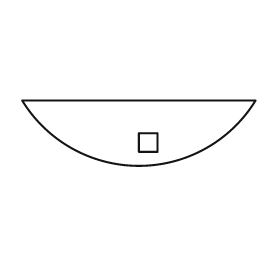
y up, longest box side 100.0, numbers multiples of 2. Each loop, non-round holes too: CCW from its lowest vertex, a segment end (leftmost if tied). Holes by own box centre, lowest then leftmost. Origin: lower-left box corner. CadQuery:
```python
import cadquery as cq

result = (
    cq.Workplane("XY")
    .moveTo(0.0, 28.0)
    .threePointArc((50.0, 0.0), (100.0, 28.0))
    .close()
    .moveTo(50.0, 6.0)
    .lineTo(58.0, 6.0)
    .lineTo(58.0, 14.0)
    .lineTo(50.0, 14.0)
    .close()
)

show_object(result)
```